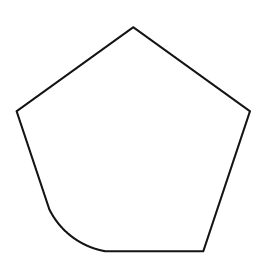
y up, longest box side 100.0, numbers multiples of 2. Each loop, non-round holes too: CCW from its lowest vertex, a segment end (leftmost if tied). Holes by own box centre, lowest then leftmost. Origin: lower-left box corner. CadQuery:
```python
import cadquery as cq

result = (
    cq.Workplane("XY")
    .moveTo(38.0, 0.0)
    .lineTo(80.0, 0.0)
    .lineTo(100.0, 60.0)
    .lineTo(50.0, 96.0)
    .lineTo(0.0, 60.0)
    .lineTo(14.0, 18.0)
    .threePointArc((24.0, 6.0), (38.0, 0.0))
    .close()
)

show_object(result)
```